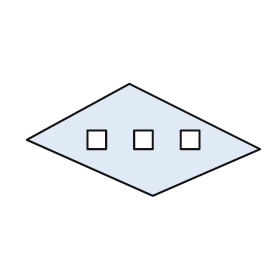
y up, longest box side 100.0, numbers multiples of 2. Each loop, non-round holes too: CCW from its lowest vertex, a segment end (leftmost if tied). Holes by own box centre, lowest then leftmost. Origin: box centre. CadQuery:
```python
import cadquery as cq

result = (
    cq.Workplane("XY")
    .moveTo(4.0, -24.0)
    .lineTo(50.0, -4.0)
    .lineTo(-6.0, 24.0)
    .lineTo(-50.0, 0.0)
    .close()
    .moveTo(-24.0, -4.0)
    .lineTo(-16.0, -4.0)
    .lineTo(-16.0, 4.0)
    .lineTo(-24.0, 4.0)
    .close()
    .moveTo(-4.0, -4.0)
    .lineTo(4.0, -4.0)
    .lineTo(4.0, 4.0)
    .lineTo(-4.0, 4.0)
    .close()
    .moveTo(16.0, -4.0)
    .lineTo(24.0, -4.0)
    .lineTo(24.0, 4.0)
    .lineTo(16.0, 4.0)
    .close()
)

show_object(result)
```